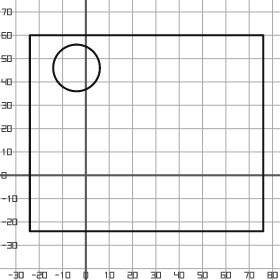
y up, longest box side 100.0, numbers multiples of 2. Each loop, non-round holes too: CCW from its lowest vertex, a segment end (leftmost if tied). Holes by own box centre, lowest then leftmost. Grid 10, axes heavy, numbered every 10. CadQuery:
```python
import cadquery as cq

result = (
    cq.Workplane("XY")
    .moveTo(-24.0, -24.0)
    .lineTo(76.0, -24.0)
    .lineTo(76.0, 60.0)
    .lineTo(-24.0, 60.0)
    .close()
    .moveTo(-4.0, 46.0)
    .circle(10.0)
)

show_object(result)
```